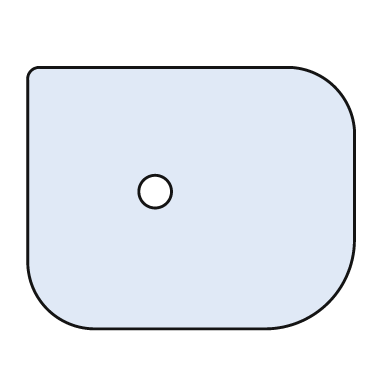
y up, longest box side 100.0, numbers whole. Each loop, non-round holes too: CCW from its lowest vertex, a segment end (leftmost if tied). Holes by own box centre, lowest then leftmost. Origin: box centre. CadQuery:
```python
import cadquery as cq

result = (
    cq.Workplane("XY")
    .moveTo(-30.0, -40.0)
    .lineTo(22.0, -40.0)
    .threePointArc((42.0, -32.0), (50.0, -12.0))
    .lineTo(50.0, 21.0)
    .threePointArc((44.0, 34.0), (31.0, 40.0))
    .lineTo(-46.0, 40.0)
    .threePointArc((-49.0, 39.0), (-50.0, 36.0))
    .lineTo(-50.0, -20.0)
    .threePointArc((-44.0, -34.0), (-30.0, -40.0))
    .close()
    .moveTo(-11.0, 2.0)
    .circle(5.0)
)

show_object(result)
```